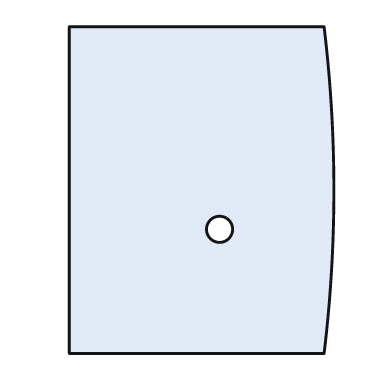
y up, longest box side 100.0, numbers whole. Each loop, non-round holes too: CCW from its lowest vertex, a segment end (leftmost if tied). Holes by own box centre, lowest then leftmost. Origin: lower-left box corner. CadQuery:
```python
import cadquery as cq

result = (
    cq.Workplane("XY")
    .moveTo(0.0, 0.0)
    .lineTo(78.0, 0.0)
    .threePointArc((81.0, 50.0), (78.0, 100.0))
    .lineTo(0.0, 100.0)
    .close()
    .moveTo(46.0, 38.0)
    .circle(4.0)
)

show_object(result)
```